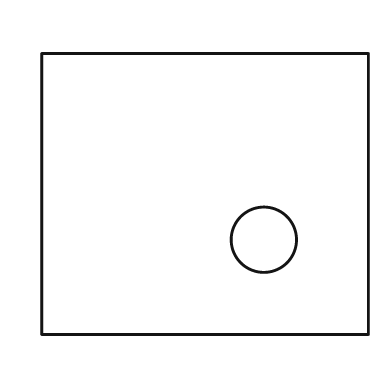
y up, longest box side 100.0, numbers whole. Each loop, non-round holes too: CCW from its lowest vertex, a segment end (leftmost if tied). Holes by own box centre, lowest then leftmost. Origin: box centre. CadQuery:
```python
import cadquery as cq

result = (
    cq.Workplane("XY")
    .moveTo(-50.0, -43.0)
    .lineTo(50.0, -43.0)
    .lineTo(50.0, 43.0)
    .lineTo(-50.0, 43.0)
    .close()
    .moveTo(18.0, -14.0)
    .circle(10.0)
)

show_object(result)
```